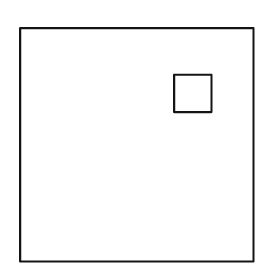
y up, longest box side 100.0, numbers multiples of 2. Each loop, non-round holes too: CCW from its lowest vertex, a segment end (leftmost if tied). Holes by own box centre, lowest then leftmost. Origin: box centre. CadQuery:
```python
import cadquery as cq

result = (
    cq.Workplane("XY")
    .moveTo(-50.0, -50.0)
    .lineTo(50.0, -50.0)
    .lineTo(50.0, 50.0)
    .lineTo(-50.0, 50.0)
    .close()
    .moveTo(16.0, 14.0)
    .lineTo(32.0, 14.0)
    .lineTo(32.0, 30.0)
    .lineTo(16.0, 30.0)
    .close()
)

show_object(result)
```